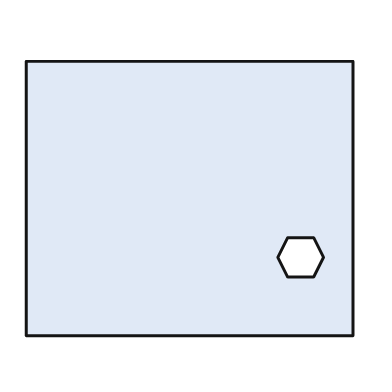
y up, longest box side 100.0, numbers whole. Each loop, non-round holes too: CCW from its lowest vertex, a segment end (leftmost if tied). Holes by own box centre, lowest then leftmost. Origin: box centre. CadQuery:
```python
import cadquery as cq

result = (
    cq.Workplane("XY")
    .moveTo(-50.0, -42.0)
    .lineTo(50.0, -42.0)
    .lineTo(50.0, 42.0)
    .lineTo(-50.0, 42.0)
    .close()
    .moveTo(30.0, -24.0)
    .lineTo(38.0, -24.0)
    .lineTo(41.0, -18.0)
    .lineTo(38.0, -12.0)
    .lineTo(30.0, -12.0)
    .lineTo(27.0, -18.0)
    .close()
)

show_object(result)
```